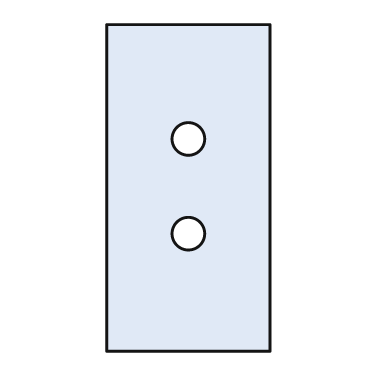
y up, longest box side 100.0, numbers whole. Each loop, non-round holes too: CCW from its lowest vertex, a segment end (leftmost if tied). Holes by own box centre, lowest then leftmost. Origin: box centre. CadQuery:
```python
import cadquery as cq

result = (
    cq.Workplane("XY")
    .moveTo(-25.0, -50.0)
    .lineTo(25.0, -50.0)
    .lineTo(25.0, 50.0)
    .lineTo(-25.0, 50.0)
    .close()
    .moveTo(0.0, -14.0)
    .circle(5.0)
    .moveTo(0.0, 15.0)
    .circle(5.0)
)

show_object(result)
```